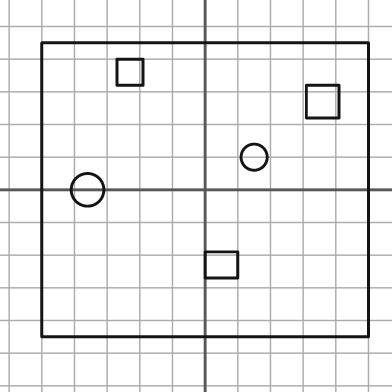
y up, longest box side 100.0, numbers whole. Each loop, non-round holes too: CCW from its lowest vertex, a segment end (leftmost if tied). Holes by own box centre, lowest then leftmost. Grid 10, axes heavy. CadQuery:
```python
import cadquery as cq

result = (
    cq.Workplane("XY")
    .moveTo(-50.0, -45.0)
    .lineTo(50.0, -45.0)
    .lineTo(50.0, 45.0)
    .lineTo(-50.0, 45.0)
    .close()
    .moveTo(0.0, -27.0)
    .lineTo(10.0, -27.0)
    .lineTo(10.0, -19.0)
    .lineTo(0.0, -19.0)
    .close()
    .moveTo(-36.0, 0.0)
    .circle(5.0)
    .moveTo(15.0, 10.0)
    .circle(4.0)
    .moveTo(31.0, 22.0)
    .lineTo(41.0, 22.0)
    .lineTo(41.0, 32.0)
    .lineTo(31.0, 32.0)
    .close()
    .moveTo(-27.0, 32.0)
    .lineTo(-19.0, 32.0)
    .lineTo(-19.0, 40.0)
    .lineTo(-27.0, 40.0)
    .close()
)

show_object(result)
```